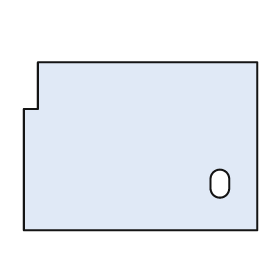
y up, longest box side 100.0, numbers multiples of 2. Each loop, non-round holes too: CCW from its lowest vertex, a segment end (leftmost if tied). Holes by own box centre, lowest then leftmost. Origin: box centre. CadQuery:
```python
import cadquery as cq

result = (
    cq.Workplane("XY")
    .moveTo(-50.0, -36.0)
    .lineTo(50.0, -36.0)
    .lineTo(50.0, 36.0)
    .lineTo(-44.0, 36.0)
    .lineTo(-44.0, 16.0)
    .lineTo(-50.0, 16.0)
    .close()
    .moveTo(30.0, -18.0)
    .threePointArc((34.0, -22.0), (38.0, -18.0))
    .lineTo(38.0, -14.0)
    .threePointArc((34.0, -10.0), (30.0, -14.0))
    .close()
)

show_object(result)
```